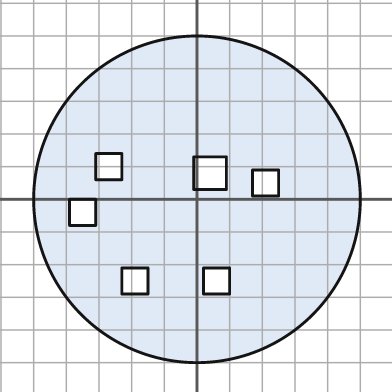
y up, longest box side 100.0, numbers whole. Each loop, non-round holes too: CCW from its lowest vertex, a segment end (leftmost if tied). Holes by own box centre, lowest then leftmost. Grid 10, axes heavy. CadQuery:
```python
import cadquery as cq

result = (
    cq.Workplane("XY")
    .moveTo(0.0, 0.0)
    .circle(50.0)
    .moveTo(-23.0, -29.0)
    .lineTo(-15.0, -29.0)
    .lineTo(-15.0, -21.0)
    .lineTo(-23.0, -21.0)
    .close()
    .moveTo(2.0, -29.0)
    .lineTo(10.0, -29.0)
    .lineTo(10.0, -21.0)
    .lineTo(2.0, -21.0)
    .close()
    .moveTo(-39.0, -8.0)
    .lineTo(-31.0, -8.0)
    .lineTo(-31.0, 0.0)
    .lineTo(-39.0, 0.0)
    .close()
    .moveTo(17.0, 1.0)
    .lineTo(25.0, 1.0)
    .lineTo(25.0, 9.0)
    .lineTo(17.0, 9.0)
    .close()
    .moveTo(-1.0, 3.0)
    .lineTo(9.0, 3.0)
    .lineTo(9.0, 13.0)
    .lineTo(-1.0, 13.0)
    .close()
    .moveTo(-31.0, 6.0)
    .lineTo(-23.0, 6.0)
    .lineTo(-23.0, 14.0)
    .lineTo(-31.0, 14.0)
    .close()
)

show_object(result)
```